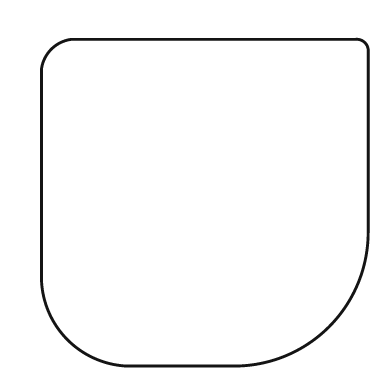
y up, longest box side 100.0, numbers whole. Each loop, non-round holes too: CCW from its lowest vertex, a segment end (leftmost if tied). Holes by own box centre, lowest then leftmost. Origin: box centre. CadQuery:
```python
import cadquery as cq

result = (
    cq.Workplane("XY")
    .moveTo(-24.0, -50.0)
    .lineTo(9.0, -50.0)
    .threePointArc((38.0, -38.0), (50.0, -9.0))
    .lineTo(50.0, 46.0)
    .threePointArc((49.0, 49.0), (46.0, 50.0))
    .lineTo(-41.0, 50.0)
    .threePointArc((-47.0, 47.0), (-50.0, 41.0))
    .lineTo(-50.0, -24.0)
    .threePointArc((-42.0, -42.0), (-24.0, -50.0))
    .close()
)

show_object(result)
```